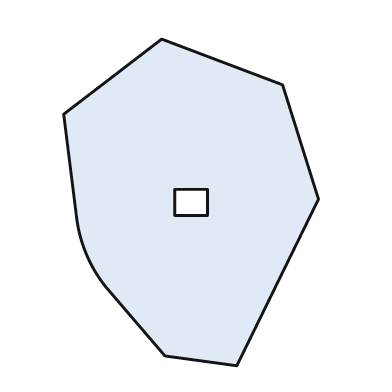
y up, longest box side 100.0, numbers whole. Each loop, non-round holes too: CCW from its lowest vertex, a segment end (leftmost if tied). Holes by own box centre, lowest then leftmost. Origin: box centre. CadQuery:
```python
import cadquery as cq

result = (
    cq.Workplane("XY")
    .moveTo(14.0, -50.0)
    .lineTo(39.0, 1.0)
    .lineTo(28.0, 36.0)
    .lineTo(-9.0, 50.0)
    .lineTo(-39.0, 27.0)
    .lineTo(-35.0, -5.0)
    .threePointArc((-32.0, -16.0), (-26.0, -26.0))
    .lineTo(-8.0, -47.0)
    .close()
    .moveTo(-5.0, -4.0)
    .lineTo(5.0, -4.0)
    .lineTo(5.0, 4.0)
    .lineTo(-5.0, 4.0)
    .close()
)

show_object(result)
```